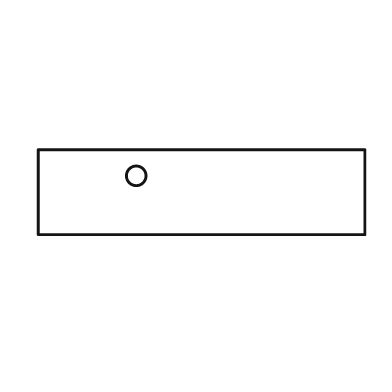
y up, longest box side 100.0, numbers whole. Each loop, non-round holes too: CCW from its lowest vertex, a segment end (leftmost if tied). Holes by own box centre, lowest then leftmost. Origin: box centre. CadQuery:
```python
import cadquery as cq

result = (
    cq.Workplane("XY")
    .moveTo(-50.0, -13.0)
    .lineTo(50.0, -13.0)
    .lineTo(50.0, 13.0)
    .lineTo(-50.0, 13.0)
    .close()
    .moveTo(-20.0, 5.0)
    .circle(3.0)
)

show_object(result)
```